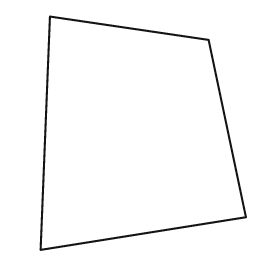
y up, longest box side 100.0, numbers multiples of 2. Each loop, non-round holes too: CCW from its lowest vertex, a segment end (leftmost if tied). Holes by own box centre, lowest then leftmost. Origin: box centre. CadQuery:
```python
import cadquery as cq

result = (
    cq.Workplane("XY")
    .moveTo(-44.0, -50.0)
    .lineTo(44.0, -36.0)
    .lineTo(28.0, 40.0)
    .lineTo(-40.0, 50.0)
    .close()
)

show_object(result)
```